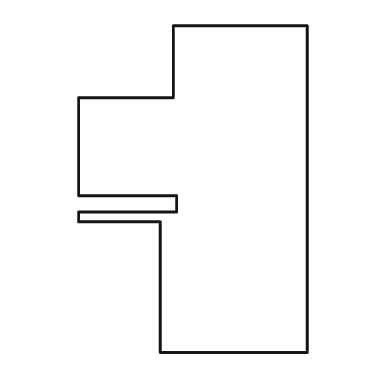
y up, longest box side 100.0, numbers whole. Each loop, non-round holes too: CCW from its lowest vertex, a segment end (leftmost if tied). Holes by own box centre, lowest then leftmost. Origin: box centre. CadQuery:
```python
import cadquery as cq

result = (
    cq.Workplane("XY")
    .moveTo(-10.0, -50.0)
    .lineTo(35.0, -50.0)
    .lineTo(35.0, 50.0)
    .lineTo(-6.0, 50.0)
    .lineTo(-6.0, 28.0)
    .lineTo(-35.0, 28.0)
    .lineTo(-35.0, -2.0)
    .lineTo(-5.0, -2.0)
    .lineTo(-5.0, -7.0)
    .lineTo(-35.0, -7.0)
    .lineTo(-35.0, -10.0)
    .lineTo(-10.0, -10.0)
    .close()
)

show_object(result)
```